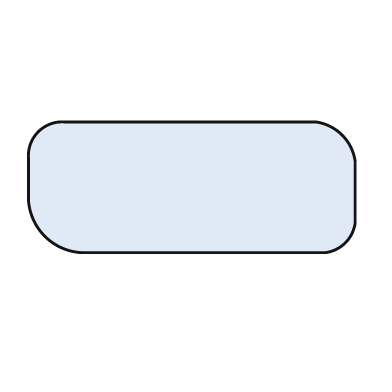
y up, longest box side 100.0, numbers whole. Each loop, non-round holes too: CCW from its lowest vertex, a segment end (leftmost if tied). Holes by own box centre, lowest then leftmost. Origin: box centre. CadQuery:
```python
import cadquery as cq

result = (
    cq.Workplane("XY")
    .moveTo(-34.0, -20.0)
    .lineTo(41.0, -20.0)
    .threePointArc((47.0, -17.0), (50.0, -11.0))
    .lineTo(50.0, 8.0)
    .threePointArc((46.0, 16.0), (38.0, 20.0))
    .lineTo(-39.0, 20.0)
    .threePointArc((-47.0, 17.0), (-50.0, 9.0))
    .lineTo(-50.0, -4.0)
    .threePointArc((-45.0, -15.0), (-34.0, -20.0))
    .close()
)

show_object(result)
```